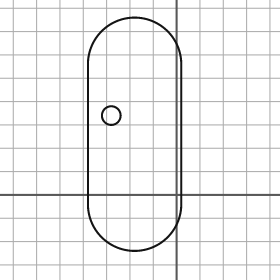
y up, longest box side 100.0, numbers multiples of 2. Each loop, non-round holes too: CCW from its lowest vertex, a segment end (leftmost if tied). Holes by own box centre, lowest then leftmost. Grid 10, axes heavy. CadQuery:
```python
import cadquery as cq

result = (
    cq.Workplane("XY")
    .moveTo(-38.0, -4.0)
    .threePointArc((-18.0, -24.0), (2.0, -4.0))
    .lineTo(2.0, 56.0)
    .threePointArc((-18.0, 76.0), (-38.0, 56.0))
    .close()
    .moveTo(-28.0, 34.0)
    .circle(4.0)
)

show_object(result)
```